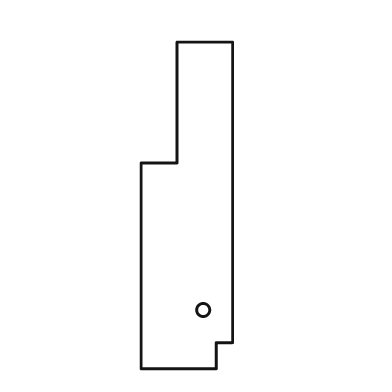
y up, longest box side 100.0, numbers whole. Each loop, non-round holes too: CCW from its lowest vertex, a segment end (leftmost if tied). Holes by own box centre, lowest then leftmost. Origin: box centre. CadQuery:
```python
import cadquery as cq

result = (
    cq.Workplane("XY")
    .moveTo(-14.0, -50.0)
    .lineTo(9.0, -50.0)
    .lineTo(9.0, -42.0)
    .lineTo(14.0, -42.0)
    .lineTo(14.0, 50.0)
    .lineTo(-3.0, 50.0)
    .lineTo(-3.0, 13.0)
    .lineTo(-14.0, 13.0)
    .close()
    .moveTo(5.0, -32.0)
    .circle(2.0)
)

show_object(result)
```